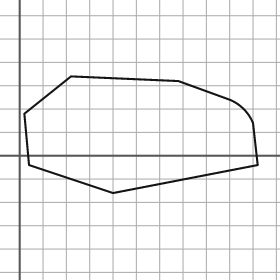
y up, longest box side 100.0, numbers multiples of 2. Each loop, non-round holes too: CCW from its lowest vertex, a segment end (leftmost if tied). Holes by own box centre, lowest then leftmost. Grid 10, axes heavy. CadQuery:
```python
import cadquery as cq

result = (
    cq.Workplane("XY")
    .moveTo(40.0, -16.0)
    .lineTo(102.0, -4.0)
    .lineTo(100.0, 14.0)
    .threePointArc((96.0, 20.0), (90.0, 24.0))
    .lineTo(68.0, 32.0)
    .lineTo(22.0, 34.0)
    .lineTo(2.0, 18.0)
    .lineTo(4.0, -4.0)
    .close()
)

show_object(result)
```